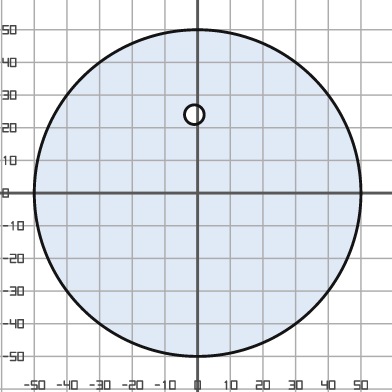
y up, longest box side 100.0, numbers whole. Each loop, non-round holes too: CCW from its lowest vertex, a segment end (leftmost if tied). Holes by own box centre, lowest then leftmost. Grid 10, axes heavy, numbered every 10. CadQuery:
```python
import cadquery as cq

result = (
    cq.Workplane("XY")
    .moveTo(0.0, 0.0)
    .circle(50.0)
    .moveTo(-1.0, 24.0)
    .circle(3.0)
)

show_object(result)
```